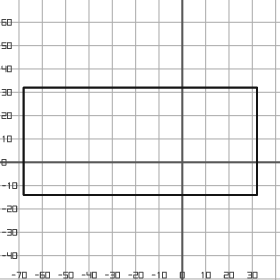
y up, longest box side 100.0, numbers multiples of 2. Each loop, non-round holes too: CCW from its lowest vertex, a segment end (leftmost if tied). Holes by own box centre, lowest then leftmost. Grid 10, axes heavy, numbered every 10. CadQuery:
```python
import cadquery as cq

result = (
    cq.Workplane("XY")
    .moveTo(-68.0, -14.0)
    .lineTo(32.0, -14.0)
    .lineTo(32.0, 32.0)
    .lineTo(-68.0, 32.0)
    .close()
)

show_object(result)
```